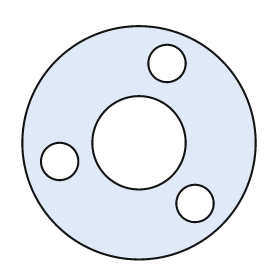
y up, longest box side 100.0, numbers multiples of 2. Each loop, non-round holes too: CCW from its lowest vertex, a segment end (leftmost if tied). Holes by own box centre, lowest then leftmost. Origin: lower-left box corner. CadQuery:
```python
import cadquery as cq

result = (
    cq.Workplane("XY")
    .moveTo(50.0, 50.0)
    .circle(50.0)
    .moveTo(74.0, 24.0)
    .circle(8.0)
    .moveTo(16.0, 42.0)
    .circle(8.0)
    .moveTo(50.0, 50.0)
    .circle(20.0)
    .moveTo(62.0, 84.0)
    .circle(8.0)
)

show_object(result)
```